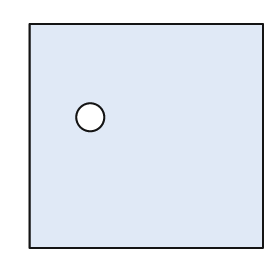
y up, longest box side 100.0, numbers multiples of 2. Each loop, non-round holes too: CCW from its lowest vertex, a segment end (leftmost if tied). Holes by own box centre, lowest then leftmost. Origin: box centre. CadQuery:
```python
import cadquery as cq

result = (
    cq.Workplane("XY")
    .moveTo(-50.0, -48.0)
    .lineTo(50.0, -48.0)
    .lineTo(50.0, 48.0)
    .lineTo(-50.0, 48.0)
    .close()
    .moveTo(-24.0, 8.0)
    .circle(6.0)
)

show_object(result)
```